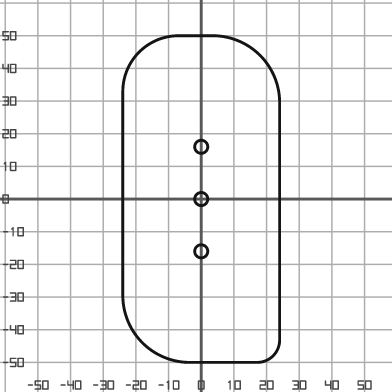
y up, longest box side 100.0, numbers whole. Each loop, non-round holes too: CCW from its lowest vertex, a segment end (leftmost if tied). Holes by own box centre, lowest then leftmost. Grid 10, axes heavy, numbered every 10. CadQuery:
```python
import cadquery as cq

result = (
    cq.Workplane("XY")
    .moveTo(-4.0, -50.0)
    .lineTo(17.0, -50.0)
    .threePointArc((22.0, -48.0), (24.0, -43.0))
    .lineTo(24.0, 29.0)
    .threePointArc((18.0, 44.0), (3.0, 50.0))
    .lineTo(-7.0, 50.0)
    .threePointArc((-19.0, 45.0), (-24.0, 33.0))
    .lineTo(-24.0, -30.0)
    .threePointArc((-18.0, -44.0), (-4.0, -50.0))
    .close()
    .moveTo(0.0, -16.0)
    .circle(2.0)
    .moveTo(0.0, 0.0)
    .circle(2.0)
    .moveTo(0.0, 16.0)
    .circle(2.0)
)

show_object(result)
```